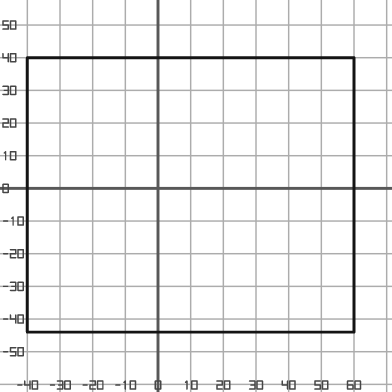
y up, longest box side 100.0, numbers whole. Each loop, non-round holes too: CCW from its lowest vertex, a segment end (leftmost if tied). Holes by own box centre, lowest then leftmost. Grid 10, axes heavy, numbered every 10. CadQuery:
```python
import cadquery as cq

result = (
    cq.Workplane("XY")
    .moveTo(-40.0, -44.0)
    .lineTo(60.0, -44.0)
    .lineTo(60.0, 40.0)
    .lineTo(-40.0, 40.0)
    .close()
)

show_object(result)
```